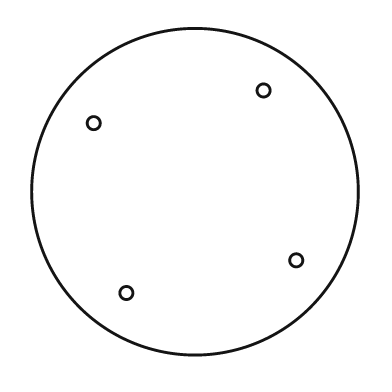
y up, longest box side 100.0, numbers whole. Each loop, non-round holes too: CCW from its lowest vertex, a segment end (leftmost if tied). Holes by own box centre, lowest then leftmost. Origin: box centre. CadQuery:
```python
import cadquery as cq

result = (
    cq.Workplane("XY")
    .moveTo(0.0, 0.0)
    .circle(50.0)
    .moveTo(-21.0, -31.0)
    .circle(2.0)
    .moveTo(31.0, -21.0)
    .circle(2.0)
    .moveTo(-31.0, 21.0)
    .circle(2.0)
    .moveTo(21.0, 31.0)
    .circle(2.0)
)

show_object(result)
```